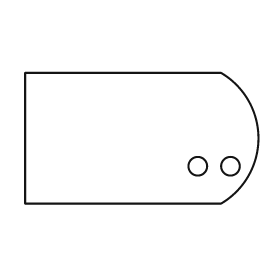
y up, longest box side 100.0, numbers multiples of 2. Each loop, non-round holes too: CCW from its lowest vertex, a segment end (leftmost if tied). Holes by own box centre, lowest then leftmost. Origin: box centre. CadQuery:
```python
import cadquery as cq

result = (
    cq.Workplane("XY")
    .moveTo(-50.0, -28.0)
    .lineTo(34.0, -28.0)
    .threePointArc((50.0, 0.0), (34.0, 28.0))
    .lineTo(-50.0, 28.0)
    .close()
    .moveTo(24.0, -12.0)
    .circle(4.0)
    .moveTo(38.0, -12.0)
    .circle(4.0)
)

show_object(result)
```